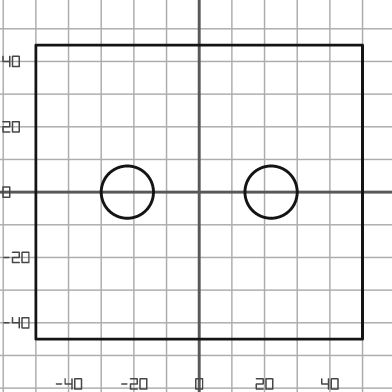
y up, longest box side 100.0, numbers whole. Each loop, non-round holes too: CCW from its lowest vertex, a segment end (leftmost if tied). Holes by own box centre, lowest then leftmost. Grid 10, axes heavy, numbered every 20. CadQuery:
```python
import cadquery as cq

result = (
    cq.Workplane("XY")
    .moveTo(-50.0, -45.0)
    .lineTo(50.0, -45.0)
    .lineTo(50.0, 45.0)
    .lineTo(-50.0, 45.0)
    .close()
    .moveTo(-22.0, 0.0)
    .circle(8.0)
    .moveTo(22.0, 0.0)
    .circle(8.0)
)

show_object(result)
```